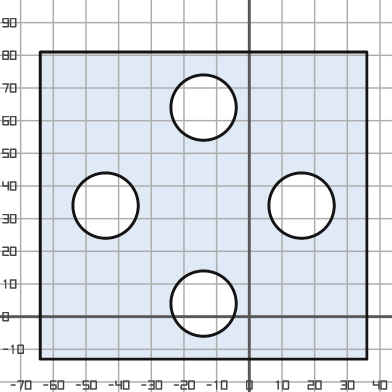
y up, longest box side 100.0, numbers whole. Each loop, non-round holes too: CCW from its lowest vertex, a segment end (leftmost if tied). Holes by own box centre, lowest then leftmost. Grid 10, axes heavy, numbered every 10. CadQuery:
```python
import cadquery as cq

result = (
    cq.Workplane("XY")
    .moveTo(-64.0, -13.0)
    .lineTo(36.0, -13.0)
    .lineTo(36.0, 81.0)
    .lineTo(-64.0, 81.0)
    .close()
    .moveTo(-14.0, 4.0)
    .circle(10.0)
    .moveTo(-44.0, 34.0)
    .circle(10.0)
    .moveTo(16.0, 34.0)
    .circle(10.0)
    .moveTo(-14.0, 64.0)
    .circle(10.0)
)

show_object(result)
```